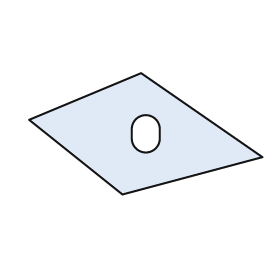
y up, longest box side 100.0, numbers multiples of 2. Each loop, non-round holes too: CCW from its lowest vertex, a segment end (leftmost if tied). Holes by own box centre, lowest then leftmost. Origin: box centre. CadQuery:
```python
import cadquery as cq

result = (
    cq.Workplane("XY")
    .moveTo(-10.0, -26.0)
    .lineTo(50.0, -10.0)
    .lineTo(-2.0, 26.0)
    .lineTo(-50.0, 6.0)
    .close()
    .moveTo(-6.0, -2.0)
    .threePointArc((0.0, -8.0), (6.0, -2.0))
    .lineTo(6.0, 2.0)
    .threePointArc((0.0, 8.0), (-6.0, 2.0))
    .close()
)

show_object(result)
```